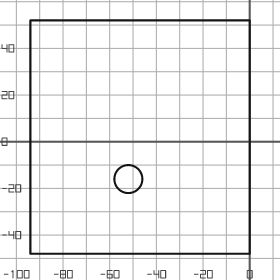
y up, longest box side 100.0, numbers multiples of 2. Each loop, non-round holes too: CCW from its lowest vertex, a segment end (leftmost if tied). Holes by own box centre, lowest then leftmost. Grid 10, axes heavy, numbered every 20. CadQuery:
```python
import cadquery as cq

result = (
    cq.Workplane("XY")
    .moveTo(-94.0, -48.0)
    .lineTo(0.0, -48.0)
    .lineTo(0.0, 52.0)
    .lineTo(-94.0, 52.0)
    .close()
    .moveTo(-52.0, -16.0)
    .circle(6.0)
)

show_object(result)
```